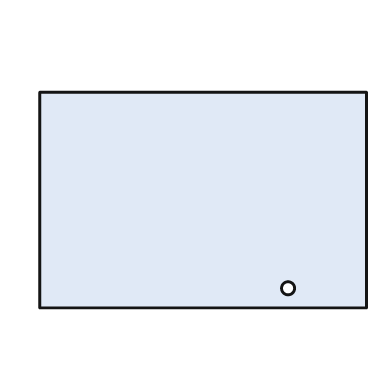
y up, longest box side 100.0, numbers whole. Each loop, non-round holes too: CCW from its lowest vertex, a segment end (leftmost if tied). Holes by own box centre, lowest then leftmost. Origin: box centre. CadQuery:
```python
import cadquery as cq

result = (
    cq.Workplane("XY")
    .moveTo(-50.0, -33.0)
    .lineTo(50.0, -33.0)
    .lineTo(50.0, 33.0)
    .lineTo(-50.0, 33.0)
    .close()
    .moveTo(26.0, -27.0)
    .circle(2.0)
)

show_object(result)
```